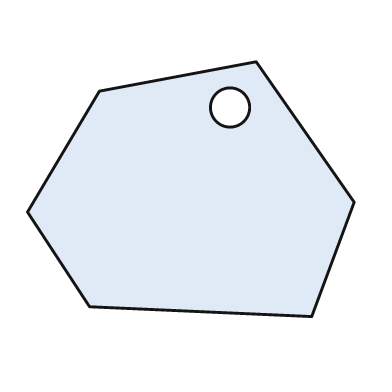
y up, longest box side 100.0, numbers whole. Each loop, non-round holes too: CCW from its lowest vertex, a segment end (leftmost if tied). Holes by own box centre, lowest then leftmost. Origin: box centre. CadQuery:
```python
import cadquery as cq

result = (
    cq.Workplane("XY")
    .moveTo(37.0, -39.0)
    .lineTo(50.0, -4.0)
    .lineTo(20.0, 39.0)
    .lineTo(-28.0, 30.0)
    .lineTo(-50.0, -7.0)
    .lineTo(-31.0, -36.0)
    .close()
    .moveTo(12.0, 25.0)
    .circle(6.0)
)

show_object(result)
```